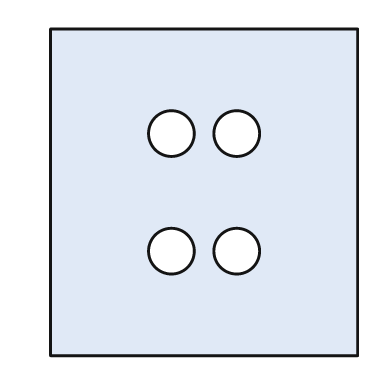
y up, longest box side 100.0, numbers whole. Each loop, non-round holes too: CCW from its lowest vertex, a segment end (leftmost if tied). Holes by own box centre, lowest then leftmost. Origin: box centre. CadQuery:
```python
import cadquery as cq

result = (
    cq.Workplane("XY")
    .moveTo(-47.0, -50.0)
    .lineTo(47.0, -50.0)
    .lineTo(47.0, 50.0)
    .lineTo(-47.0, 50.0)
    .close()
    .moveTo(-10.0, -18.0)
    .circle(7.0)
    .moveTo(10.0, -18.0)
    .circle(7.0)
    .moveTo(-10.0, 18.0)
    .circle(7.0)
    .moveTo(10.0, 18.0)
    .circle(7.0)
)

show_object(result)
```